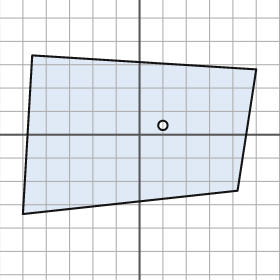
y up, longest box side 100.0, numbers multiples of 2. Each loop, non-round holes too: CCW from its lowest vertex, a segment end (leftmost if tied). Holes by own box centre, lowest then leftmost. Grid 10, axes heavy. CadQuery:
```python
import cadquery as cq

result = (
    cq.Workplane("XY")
    .moveTo(-50.0, -34.0)
    .lineTo(42.0, -24.0)
    .lineTo(50.0, 28.0)
    .lineTo(-46.0, 34.0)
    .close()
    .moveTo(10.0, 4.0)
    .circle(2.0)
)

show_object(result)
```